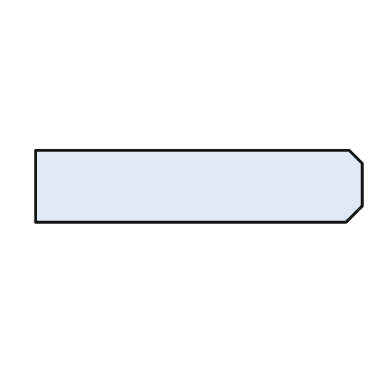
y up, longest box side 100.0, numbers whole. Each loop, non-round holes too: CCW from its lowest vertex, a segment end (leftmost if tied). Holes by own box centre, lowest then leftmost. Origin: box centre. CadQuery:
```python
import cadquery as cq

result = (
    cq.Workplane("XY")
    .moveTo(-50.0, -11.0)
    .lineTo(45.0, -11.0)
    .lineTo(50.0, -6.0)
    .lineTo(50.0, 7.0)
    .lineTo(46.0, 11.0)
    .lineTo(-50.0, 11.0)
    .close()
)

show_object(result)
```